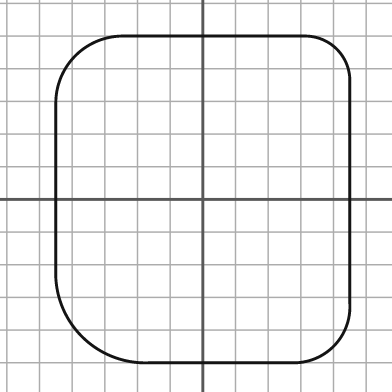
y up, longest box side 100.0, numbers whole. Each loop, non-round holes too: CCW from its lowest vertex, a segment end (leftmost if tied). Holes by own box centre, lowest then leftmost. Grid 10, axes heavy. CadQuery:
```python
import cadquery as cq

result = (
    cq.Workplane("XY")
    .moveTo(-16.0, -50.0)
    .lineTo(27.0, -50.0)
    .threePointArc((40.0, -45.0), (45.0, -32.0))
    .lineTo(45.0, 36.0)
    .threePointArc((41.0, 46.0), (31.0, 50.0))
    .lineTo(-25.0, 50.0)
    .threePointArc((-39.0, 44.0), (-45.0, 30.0))
    .lineTo(-45.0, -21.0)
    .threePointArc((-37.0, -42.0), (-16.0, -50.0))
    .close()
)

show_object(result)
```